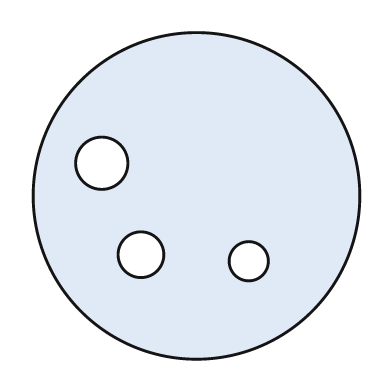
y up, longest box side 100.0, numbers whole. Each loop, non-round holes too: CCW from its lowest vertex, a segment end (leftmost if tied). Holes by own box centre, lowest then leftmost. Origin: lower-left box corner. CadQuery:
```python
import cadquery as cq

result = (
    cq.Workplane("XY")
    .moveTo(50.0, 50.0)
    .circle(50.0)
    .moveTo(66.0, 30.0)
    .circle(6.0)
    .moveTo(33.0, 32.0)
    .circle(7.0)
    .moveTo(21.0, 60.0)
    .circle(8.0)
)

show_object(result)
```